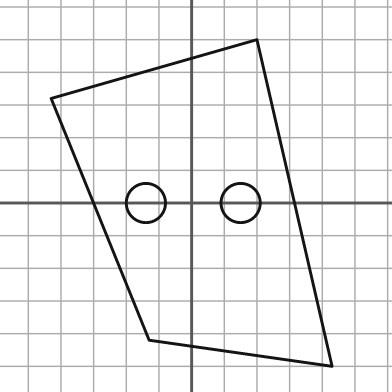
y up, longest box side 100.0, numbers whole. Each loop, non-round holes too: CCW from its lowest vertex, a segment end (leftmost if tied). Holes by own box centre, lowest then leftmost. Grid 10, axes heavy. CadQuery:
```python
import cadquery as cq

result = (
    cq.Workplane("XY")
    .moveTo(43.0, -50.0)
    .lineTo(20.0, 50.0)
    .lineTo(-43.0, 32.0)
    .lineTo(-13.0, -42.0)
    .close()
    .moveTo(-14.0, 0.0)
    .circle(6.0)
    .moveTo(15.0, 0.0)
    .circle(6.0)
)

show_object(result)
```